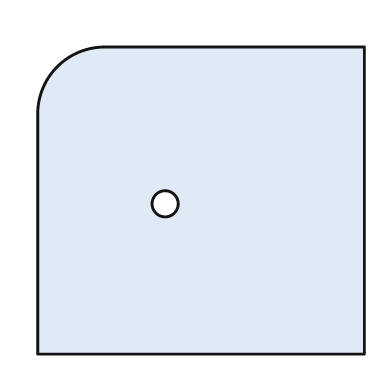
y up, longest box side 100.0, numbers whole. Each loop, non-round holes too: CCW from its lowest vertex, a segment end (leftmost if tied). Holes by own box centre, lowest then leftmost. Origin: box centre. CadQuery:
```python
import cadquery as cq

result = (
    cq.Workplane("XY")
    .moveTo(-50.0, -47.0)
    .lineTo(50.0, -47.0)
    .lineTo(50.0, 47.0)
    .lineTo(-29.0, 47.0)
    .threePointArc((-44.0, 41.0), (-50.0, 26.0))
    .close()
    .moveTo(-11.0, -1.0)
    .circle(4.0)
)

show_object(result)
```